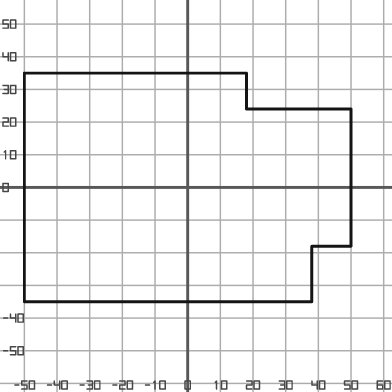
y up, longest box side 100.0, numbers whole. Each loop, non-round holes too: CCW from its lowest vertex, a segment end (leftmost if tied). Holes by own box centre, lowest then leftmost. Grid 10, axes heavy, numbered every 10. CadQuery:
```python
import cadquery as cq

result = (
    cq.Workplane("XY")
    .moveTo(-50.0, -35.0)
    .lineTo(38.0, -35.0)
    .lineTo(38.0, -18.0)
    .lineTo(50.0, -18.0)
    .lineTo(50.0, 24.0)
    .lineTo(18.0, 24.0)
    .lineTo(18.0, 35.0)
    .lineTo(-50.0, 35.0)
    .close()
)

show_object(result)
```